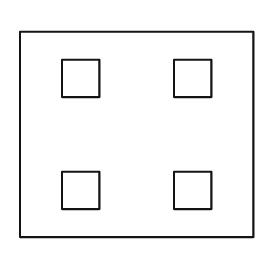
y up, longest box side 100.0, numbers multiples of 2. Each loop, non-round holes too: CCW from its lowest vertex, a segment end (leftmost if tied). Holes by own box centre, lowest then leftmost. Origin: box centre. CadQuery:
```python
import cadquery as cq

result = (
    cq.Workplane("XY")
    .moveTo(-50.0, -44.0)
    .lineTo(50.0, -44.0)
    .lineTo(50.0, 44.0)
    .lineTo(-50.0, 44.0)
    .close()
    .moveTo(-32.0, -32.0)
    .lineTo(-16.0, -32.0)
    .lineTo(-16.0, -16.0)
    .lineTo(-32.0, -16.0)
    .close()
    .moveTo(16.0, -32.0)
    .lineTo(32.0, -32.0)
    .lineTo(32.0, -16.0)
    .lineTo(16.0, -16.0)
    .close()
    .moveTo(-32.0, 16.0)
    .lineTo(-16.0, 16.0)
    .lineTo(-16.0, 32.0)
    .lineTo(-32.0, 32.0)
    .close()
    .moveTo(16.0, 16.0)
    .lineTo(32.0, 16.0)
    .lineTo(32.0, 32.0)
    .lineTo(16.0, 32.0)
    .close()
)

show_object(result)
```